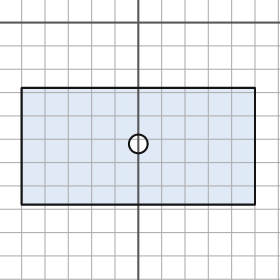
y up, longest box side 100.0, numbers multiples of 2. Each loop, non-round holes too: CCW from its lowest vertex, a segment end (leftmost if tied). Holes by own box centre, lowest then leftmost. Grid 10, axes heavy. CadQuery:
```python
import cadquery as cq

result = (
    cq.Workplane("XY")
    .moveTo(-50.0, -78.0)
    .lineTo(50.0, -78.0)
    .lineTo(50.0, -28.0)
    .lineTo(-50.0, -28.0)
    .close()
    .moveTo(0.0, -52.0)
    .circle(4.0)
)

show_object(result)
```